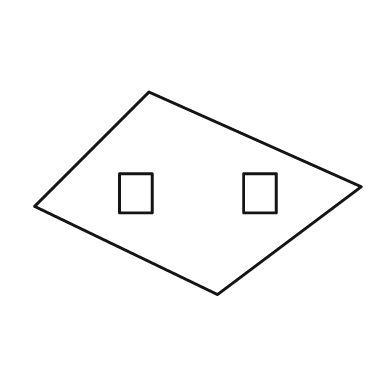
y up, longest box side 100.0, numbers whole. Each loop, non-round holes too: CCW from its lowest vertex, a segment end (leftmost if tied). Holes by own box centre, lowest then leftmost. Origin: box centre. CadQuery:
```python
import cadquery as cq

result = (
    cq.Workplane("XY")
    .moveTo(6.0, -31.0)
    .lineTo(50.0, 2.0)
    .lineTo(-15.0, 31.0)
    .lineTo(-50.0, -4.0)
    .close()
    .moveTo(-24.0, -6.0)
    .lineTo(-14.0, -6.0)
    .lineTo(-14.0, 6.0)
    .lineTo(-24.0, 6.0)
    .close()
    .moveTo(14.0, -6.0)
    .lineTo(24.0, -6.0)
    .lineTo(24.0, 6.0)
    .lineTo(14.0, 6.0)
    .close()
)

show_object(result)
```